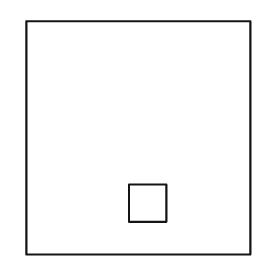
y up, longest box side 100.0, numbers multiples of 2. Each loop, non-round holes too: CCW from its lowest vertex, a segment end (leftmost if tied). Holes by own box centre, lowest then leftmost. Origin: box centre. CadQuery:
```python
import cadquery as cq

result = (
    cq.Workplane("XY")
    .moveTo(-48.0, -50.0)
    .lineTo(48.0, -50.0)
    .lineTo(48.0, 50.0)
    .lineTo(-48.0, 50.0)
    .close()
    .moveTo(-4.0, -36.0)
    .lineTo(12.0, -36.0)
    .lineTo(12.0, -20.0)
    .lineTo(-4.0, -20.0)
    .close()
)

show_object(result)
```